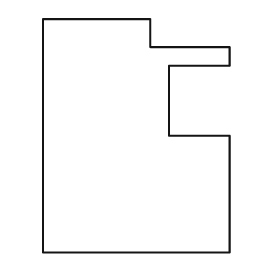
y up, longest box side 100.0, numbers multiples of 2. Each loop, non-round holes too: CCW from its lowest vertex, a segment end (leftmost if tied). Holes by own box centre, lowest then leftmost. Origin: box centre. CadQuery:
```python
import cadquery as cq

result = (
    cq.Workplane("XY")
    .moveTo(-40.0, -50.0)
    .lineTo(40.0, -50.0)
    .lineTo(40.0, 0.0)
    .lineTo(14.0, 0.0)
    .lineTo(14.0, 30.0)
    .lineTo(40.0, 30.0)
    .lineTo(40.0, 38.0)
    .lineTo(6.0, 38.0)
    .lineTo(6.0, 50.0)
    .lineTo(-40.0, 50.0)
    .close()
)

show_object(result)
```